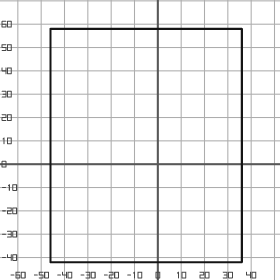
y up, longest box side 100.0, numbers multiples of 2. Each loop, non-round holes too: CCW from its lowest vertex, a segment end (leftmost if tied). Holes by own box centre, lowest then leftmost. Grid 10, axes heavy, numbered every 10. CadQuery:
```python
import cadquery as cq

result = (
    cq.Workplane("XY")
    .moveTo(-46.0, -42.0)
    .lineTo(36.0, -42.0)
    .lineTo(36.0, 58.0)
    .lineTo(-46.0, 58.0)
    .close()
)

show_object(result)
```